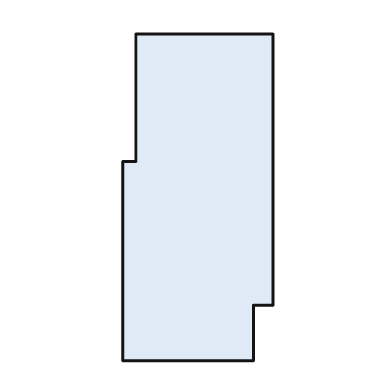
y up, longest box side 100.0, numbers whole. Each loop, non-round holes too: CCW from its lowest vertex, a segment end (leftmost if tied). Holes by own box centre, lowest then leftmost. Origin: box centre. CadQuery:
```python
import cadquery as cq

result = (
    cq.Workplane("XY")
    .moveTo(-23.0, -50.0)
    .lineTo(17.0, -50.0)
    .lineTo(17.0, -33.0)
    .lineTo(23.0, -33.0)
    .lineTo(23.0, 50.0)
    .lineTo(-19.0, 50.0)
    .lineTo(-19.0, 11.0)
    .lineTo(-23.0, 11.0)
    .close()
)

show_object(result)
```